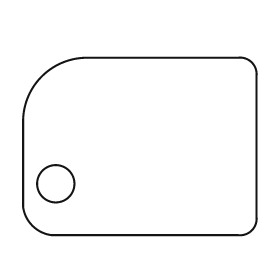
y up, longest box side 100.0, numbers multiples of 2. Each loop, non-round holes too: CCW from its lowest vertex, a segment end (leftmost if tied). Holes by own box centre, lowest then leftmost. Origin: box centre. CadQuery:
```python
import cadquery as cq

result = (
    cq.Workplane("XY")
    .moveTo(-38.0, -38.0)
    .lineTo(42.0, -38.0)
    .threePointArc((48.0, -36.0), (50.0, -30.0))
    .lineTo(50.0, 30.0)
    .threePointArc((48.0, 36.0), (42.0, 38.0))
    .lineTo(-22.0, 38.0)
    .threePointArc((-42.0, 30.0), (-50.0, 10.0))
    .lineTo(-50.0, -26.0)
    .threePointArc((-46.0, -34.0), (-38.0, -38.0))
    .close()
    .moveTo(-36.0, -16.0)
    .circle(8.0)
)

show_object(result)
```